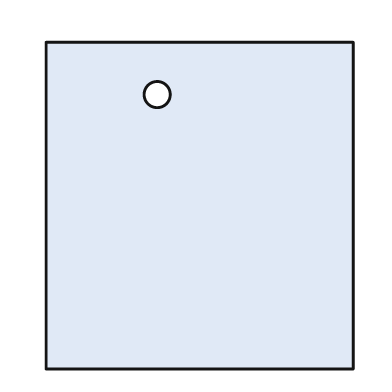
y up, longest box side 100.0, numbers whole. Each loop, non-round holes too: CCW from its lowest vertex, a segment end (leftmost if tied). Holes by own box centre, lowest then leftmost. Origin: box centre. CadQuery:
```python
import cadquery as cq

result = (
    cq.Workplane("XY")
    .moveTo(-47.0, -50.0)
    .lineTo(47.0, -50.0)
    .lineTo(47.0, 50.0)
    .lineTo(-47.0, 50.0)
    .close()
    .moveTo(-13.0, 34.0)
    .circle(4.0)
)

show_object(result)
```